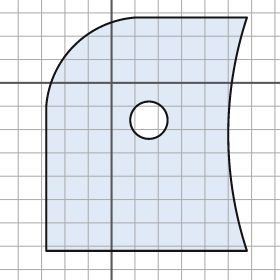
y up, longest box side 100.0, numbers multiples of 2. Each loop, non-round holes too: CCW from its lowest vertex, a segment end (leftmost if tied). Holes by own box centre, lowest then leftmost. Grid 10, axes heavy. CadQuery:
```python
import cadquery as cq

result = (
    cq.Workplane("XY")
    .moveTo(-28.0, -72.0)
    .lineTo(58.0, -72.0)
    .threePointArc((50.0, -22.0), (58.0, 28.0))
    .lineTo(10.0, 28.0)
    .threePointArc((-16.0, 16.0), (-28.0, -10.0))
    .close()
    .moveTo(16.0, -16.0)
    .circle(8.0)
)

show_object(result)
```